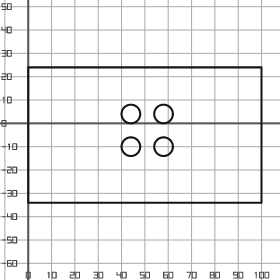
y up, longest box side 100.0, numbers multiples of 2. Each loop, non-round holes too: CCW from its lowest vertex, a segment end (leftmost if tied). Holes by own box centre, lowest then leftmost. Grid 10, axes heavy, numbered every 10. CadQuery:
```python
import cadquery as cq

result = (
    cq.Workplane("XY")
    .moveTo(0.0, -34.0)
    .lineTo(100.0, -34.0)
    .lineTo(100.0, 24.0)
    .lineTo(0.0, 24.0)
    .close()
    .moveTo(44.0, -10.0)
    .circle(4.0)
    .moveTo(58.0, -10.0)
    .circle(4.0)
    .moveTo(44.0, 4.0)
    .circle(4.0)
    .moveTo(58.0, 4.0)
    .circle(4.0)
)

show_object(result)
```